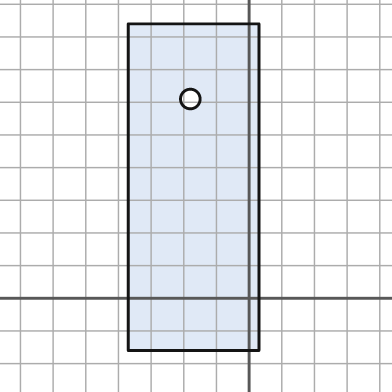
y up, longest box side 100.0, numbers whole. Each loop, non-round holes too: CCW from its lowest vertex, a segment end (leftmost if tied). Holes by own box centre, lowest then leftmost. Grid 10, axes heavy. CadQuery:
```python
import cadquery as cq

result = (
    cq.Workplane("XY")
    .moveTo(-37.0, -16.0)
    .lineTo(3.0, -16.0)
    .lineTo(3.0, 84.0)
    .lineTo(-37.0, 84.0)
    .close()
    .moveTo(-18.0, 61.0)
    .circle(3.0)
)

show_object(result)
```